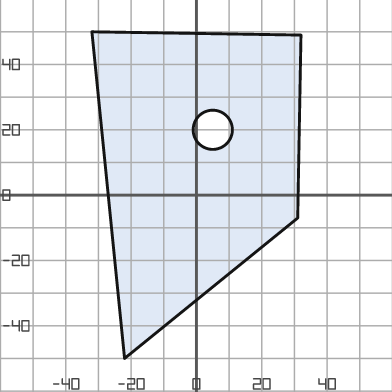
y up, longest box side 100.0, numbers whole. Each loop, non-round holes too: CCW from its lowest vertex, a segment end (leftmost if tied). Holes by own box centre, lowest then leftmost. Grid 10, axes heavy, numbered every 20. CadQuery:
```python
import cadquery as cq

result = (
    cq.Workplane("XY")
    .moveTo(-22.0, -50.0)
    .lineTo(31.0, -7.0)
    .lineTo(32.0, 49.0)
    .lineTo(-32.0, 50.0)
    .close()
    .moveTo(5.0, 20.0)
    .circle(6.0)
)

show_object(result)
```